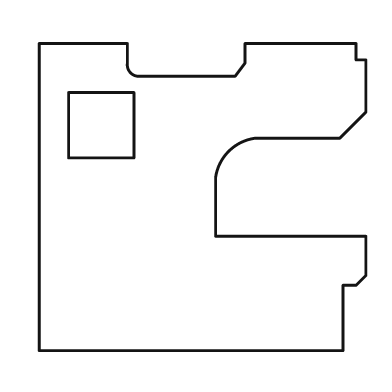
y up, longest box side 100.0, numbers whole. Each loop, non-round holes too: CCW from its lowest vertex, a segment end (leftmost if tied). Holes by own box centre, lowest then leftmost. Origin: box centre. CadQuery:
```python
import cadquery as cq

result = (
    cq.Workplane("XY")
    .moveTo(-50.0, -47.0)
    .lineTo(43.0, -47.0)
    .lineTo(43.0, -27.0)
    .lineTo(47.0, -27.0)
    .lineTo(50.0, -24.0)
    .lineTo(50.0, -12.0)
    .lineTo(4.0, -12.0)
    .lineTo(4.0, 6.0)
    .threePointArc((8.0, 14.0), (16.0, 18.0))
    .lineTo(42.0, 18.0)
    .lineTo(50.0, 26.0)
    .lineTo(50.0, 42.0)
    .lineTo(47.0, 42.0)
    .lineTo(47.0, 47.0)
    .lineTo(13.0, 47.0)
    .lineTo(13.0, 41.0)
    .lineTo(10.0, 37.0)
    .lineTo(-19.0, 37.0)
    .threePointArc((-22.0, 38.0), (-23.0, 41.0))
    .lineTo(-23.0, 47.0)
    .lineTo(-50.0, 47.0)
    .close()
    .moveTo(-41.0, 12.0)
    .lineTo(-21.0, 12.0)
    .lineTo(-21.0, 32.0)
    .lineTo(-41.0, 32.0)
    .close()
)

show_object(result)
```